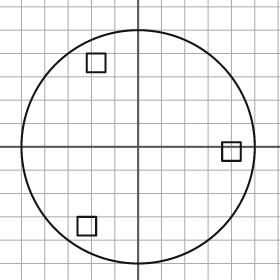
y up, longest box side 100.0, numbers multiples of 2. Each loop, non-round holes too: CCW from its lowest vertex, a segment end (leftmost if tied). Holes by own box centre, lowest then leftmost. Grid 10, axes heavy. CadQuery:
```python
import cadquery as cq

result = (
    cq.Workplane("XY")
    .moveTo(0.0, 0.0)
    .circle(50.0)
    .moveTo(-26.0, -38.0)
    .lineTo(-18.0, -38.0)
    .lineTo(-18.0, -30.0)
    .lineTo(-26.0, -30.0)
    .close()
    .moveTo(36.0, -6.0)
    .lineTo(44.0, -6.0)
    .lineTo(44.0, 2.0)
    .lineTo(36.0, 2.0)
    .close()
    .moveTo(-22.0, 32.0)
    .lineTo(-14.0, 32.0)
    .lineTo(-14.0, 40.0)
    .lineTo(-22.0, 40.0)
    .close()
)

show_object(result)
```